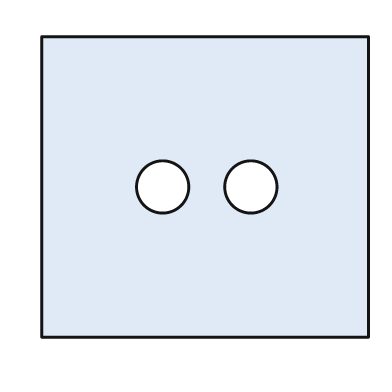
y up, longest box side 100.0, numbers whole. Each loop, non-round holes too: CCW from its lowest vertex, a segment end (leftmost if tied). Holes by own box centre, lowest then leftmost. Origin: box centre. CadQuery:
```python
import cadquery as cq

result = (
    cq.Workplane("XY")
    .moveTo(-50.0, -46.0)
    .lineTo(50.0, -46.0)
    .lineTo(50.0, 46.0)
    .lineTo(-50.0, 46.0)
    .close()
    .moveTo(-13.0, 0.0)
    .circle(8.0)
    .moveTo(14.0, 0.0)
    .circle(8.0)
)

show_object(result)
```